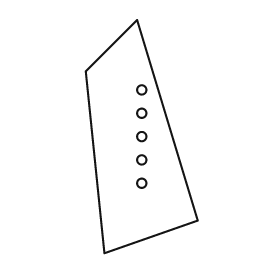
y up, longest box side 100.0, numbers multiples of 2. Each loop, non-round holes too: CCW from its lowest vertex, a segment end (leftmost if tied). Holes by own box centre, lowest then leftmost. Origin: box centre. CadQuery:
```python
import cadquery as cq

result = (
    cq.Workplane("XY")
    .moveTo(-16.0, -50.0)
    .lineTo(24.0, -36.0)
    .lineTo(-2.0, 50.0)
    .lineTo(-24.0, 28.0)
    .close()
    .moveTo(0.0, -20.0)
    .circle(2.0)
    .moveTo(0.0, -10.0)
    .circle(2.0)
    .moveTo(0.0, 0.0)
    .circle(2.0)
    .moveTo(0.0, 10.0)
    .circle(2.0)
    .moveTo(0.0, 20.0)
    .circle(2.0)
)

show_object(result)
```